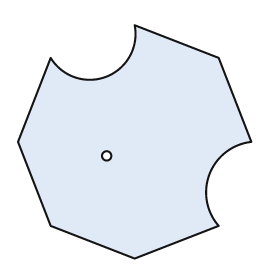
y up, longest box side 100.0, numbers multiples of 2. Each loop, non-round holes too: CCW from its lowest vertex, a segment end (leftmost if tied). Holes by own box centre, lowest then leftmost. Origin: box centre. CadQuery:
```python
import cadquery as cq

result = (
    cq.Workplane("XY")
    .moveTo(0.0, -50.0)
    .lineTo(36.0, -36.0)
    .threePointArc((32.0, -14.0), (50.0, 0.0))
    .lineTo(36.0, 36.0)
    .lineTo(0.0, 50.0)
    .threePointArc((-12.0, 28.0), (-36.0, 36.0))
    .lineTo(-50.0, 0.0)
    .lineTo(-36.0, -36.0)
    .close()
    .moveTo(-12.0, -6.0)
    .circle(2.0)
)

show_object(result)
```